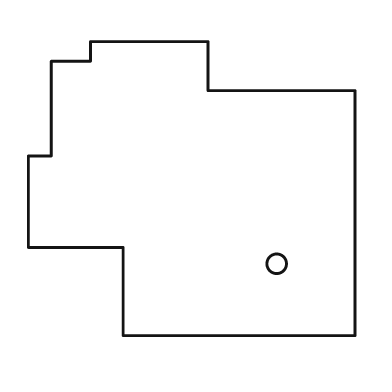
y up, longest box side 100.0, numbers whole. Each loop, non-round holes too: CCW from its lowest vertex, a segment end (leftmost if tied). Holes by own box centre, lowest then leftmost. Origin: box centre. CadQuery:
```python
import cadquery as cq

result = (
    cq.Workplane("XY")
    .moveTo(-21.0, -45.0)
    .lineTo(50.0, -45.0)
    .lineTo(50.0, 30.0)
    .lineTo(5.0, 30.0)
    .lineTo(5.0, 45.0)
    .lineTo(-31.0, 45.0)
    .lineTo(-31.0, 39.0)
    .lineTo(-43.0, 39.0)
    .lineTo(-43.0, 10.0)
    .lineTo(-50.0, 10.0)
    .lineTo(-50.0, -18.0)
    .lineTo(-21.0, -18.0)
    .close()
    .moveTo(26.0, -23.0)
    .circle(3.0)
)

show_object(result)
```